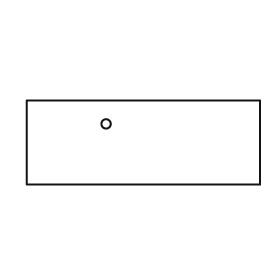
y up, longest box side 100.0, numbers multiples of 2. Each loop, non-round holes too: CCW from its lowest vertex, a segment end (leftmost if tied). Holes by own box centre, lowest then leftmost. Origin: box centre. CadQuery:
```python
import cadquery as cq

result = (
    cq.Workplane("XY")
    .moveTo(-50.0, -18.0)
    .lineTo(50.0, -18.0)
    .lineTo(50.0, 18.0)
    .lineTo(-50.0, 18.0)
    .close()
    .moveTo(-16.0, 8.0)
    .circle(2.0)
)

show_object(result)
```